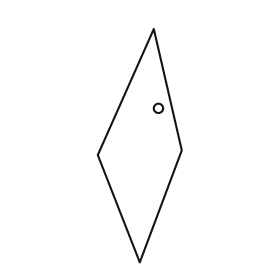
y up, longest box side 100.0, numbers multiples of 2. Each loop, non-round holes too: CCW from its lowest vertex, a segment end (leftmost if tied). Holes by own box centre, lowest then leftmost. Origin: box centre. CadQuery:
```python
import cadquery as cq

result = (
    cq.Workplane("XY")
    .moveTo(0.0, -50.0)
    .lineTo(18.0, -2.0)
    .lineTo(6.0, 50.0)
    .lineTo(-18.0, -4.0)
    .close()
    .moveTo(8.0, 16.0)
    .circle(2.0)
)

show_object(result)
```